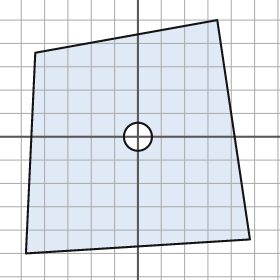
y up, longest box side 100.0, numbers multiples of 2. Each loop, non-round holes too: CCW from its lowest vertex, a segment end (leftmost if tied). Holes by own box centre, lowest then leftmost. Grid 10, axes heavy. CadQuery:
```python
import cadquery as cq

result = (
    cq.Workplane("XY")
    .moveTo(-48.0, -50.0)
    .lineTo(48.0, -44.0)
    .lineTo(34.0, 50.0)
    .lineTo(-44.0, 36.0)
    .close()
    .moveTo(0.0, 0.0)
    .circle(6.0)
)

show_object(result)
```